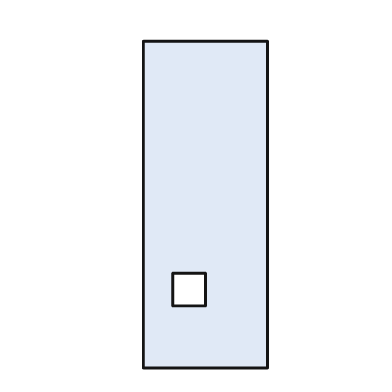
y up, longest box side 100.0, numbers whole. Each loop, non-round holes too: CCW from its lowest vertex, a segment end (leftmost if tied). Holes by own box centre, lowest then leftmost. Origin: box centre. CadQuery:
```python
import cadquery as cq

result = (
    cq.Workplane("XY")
    .moveTo(-19.0, -50.0)
    .lineTo(19.0, -50.0)
    .lineTo(19.0, 50.0)
    .lineTo(-19.0, 50.0)
    .close()
    .moveTo(-10.0, -31.0)
    .lineTo(0.0, -31.0)
    .lineTo(0.0, -21.0)
    .lineTo(-10.0, -21.0)
    .close()
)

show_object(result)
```